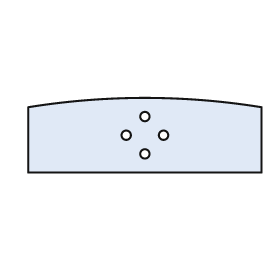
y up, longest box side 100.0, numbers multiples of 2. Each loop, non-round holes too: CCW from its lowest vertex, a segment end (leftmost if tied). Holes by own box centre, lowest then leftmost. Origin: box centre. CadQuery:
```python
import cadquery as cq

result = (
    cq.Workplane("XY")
    .moveTo(-50.0, -16.0)
    .lineTo(50.0, -16.0)
    .lineTo(50.0, 12.0)
    .threePointArc((0.0, 16.0), (-50.0, 12.0))
    .close()
    .moveTo(0.0, -8.0)
    .circle(2.0)
    .moveTo(-8.0, 0.0)
    .circle(2.0)
    .moveTo(8.0, 0.0)
    .circle(2.0)
    .moveTo(0.0, 8.0)
    .circle(2.0)
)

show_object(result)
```